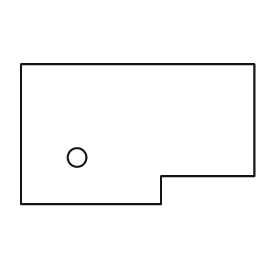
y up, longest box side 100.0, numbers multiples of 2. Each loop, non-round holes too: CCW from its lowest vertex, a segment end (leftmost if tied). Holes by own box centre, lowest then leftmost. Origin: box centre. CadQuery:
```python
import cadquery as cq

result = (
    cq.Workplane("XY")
    .moveTo(-50.0, -30.0)
    .lineTo(10.0, -30.0)
    .lineTo(10.0, -18.0)
    .lineTo(50.0, -18.0)
    .lineTo(50.0, 30.0)
    .lineTo(-50.0, 30.0)
    .close()
    .moveTo(-26.0, -10.0)
    .circle(4.0)
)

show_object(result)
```